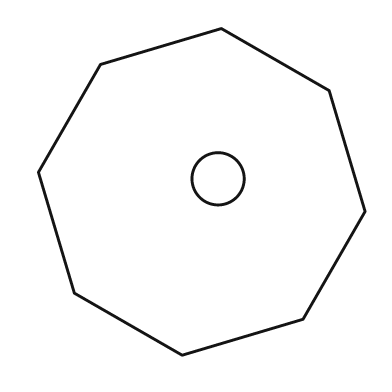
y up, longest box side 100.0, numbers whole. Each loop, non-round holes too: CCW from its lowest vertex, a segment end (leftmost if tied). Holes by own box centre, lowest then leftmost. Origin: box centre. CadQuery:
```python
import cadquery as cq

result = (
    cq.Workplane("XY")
    .moveTo(-6.0, -50.0)
    .lineTo(31.0, -39.0)
    .lineTo(50.0, -6.0)
    .lineTo(39.0, 31.0)
    .lineTo(6.0, 50.0)
    .lineTo(-31.0, 39.0)
    .lineTo(-50.0, 6.0)
    .lineTo(-39.0, -31.0)
    .close()
    .moveTo(5.0, 4.0)
    .circle(8.0)
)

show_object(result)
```